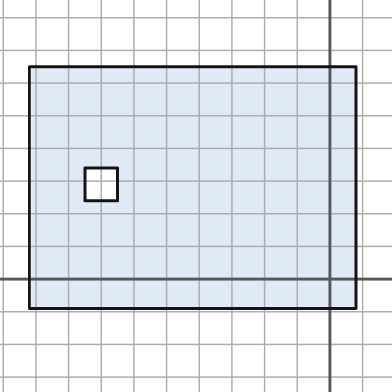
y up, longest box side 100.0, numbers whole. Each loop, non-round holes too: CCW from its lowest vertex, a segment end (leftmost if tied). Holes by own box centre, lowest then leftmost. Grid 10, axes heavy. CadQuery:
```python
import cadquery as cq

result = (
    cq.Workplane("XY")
    .moveTo(-92.0, -9.0)
    .lineTo(8.0, -9.0)
    .lineTo(8.0, 65.0)
    .lineTo(-92.0, 65.0)
    .close()
    .moveTo(-75.0, 24.0)
    .lineTo(-65.0, 24.0)
    .lineTo(-65.0, 34.0)
    .lineTo(-75.0, 34.0)
    .close()
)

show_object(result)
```